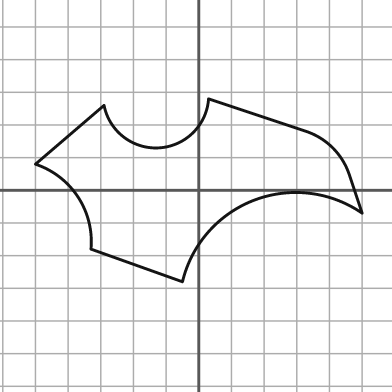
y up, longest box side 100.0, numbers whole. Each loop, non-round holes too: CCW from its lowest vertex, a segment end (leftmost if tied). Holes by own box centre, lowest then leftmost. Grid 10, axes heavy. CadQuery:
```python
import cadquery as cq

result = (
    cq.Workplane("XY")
    .moveTo(-5.0, -28.0)
    .threePointArc((17.0, -3.0), (50.0, -7.0))
    .lineTo(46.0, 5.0)
    .threePointArc((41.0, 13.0), (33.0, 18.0))
    .lineTo(3.0, 28.0)
    .threePointArc((-12.0, 13.0), (-29.0, 26.0))
    .lineTo(-50.0, 8.0)
    .threePointArc((-37.0, -2.0), (-33.0, -18.0))
    .close()
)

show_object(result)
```